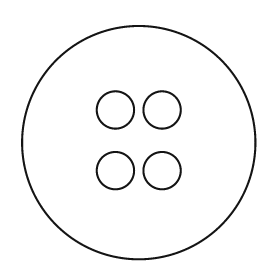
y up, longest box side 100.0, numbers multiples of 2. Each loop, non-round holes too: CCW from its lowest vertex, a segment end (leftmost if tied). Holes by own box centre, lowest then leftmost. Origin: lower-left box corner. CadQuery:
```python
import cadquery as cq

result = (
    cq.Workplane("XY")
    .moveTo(50.0, 50.0)
    .circle(50.0)
    .moveTo(40.0, 38.0)
    .circle(8.0)
    .moveTo(60.0, 38.0)
    .circle(8.0)
    .moveTo(40.0, 64.0)
    .circle(8.0)
    .moveTo(60.0, 64.0)
    .circle(8.0)
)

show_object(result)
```